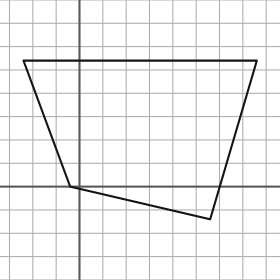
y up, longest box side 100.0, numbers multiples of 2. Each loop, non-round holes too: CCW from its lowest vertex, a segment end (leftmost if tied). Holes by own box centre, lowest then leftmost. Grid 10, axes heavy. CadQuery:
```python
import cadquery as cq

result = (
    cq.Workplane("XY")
    .moveTo(56.0, -14.0)
    .lineTo(76.0, 54.0)
    .lineTo(-24.0, 54.0)
    .lineTo(-4.0, 0.0)
    .close()
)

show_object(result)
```